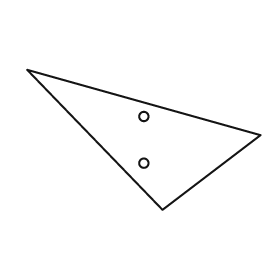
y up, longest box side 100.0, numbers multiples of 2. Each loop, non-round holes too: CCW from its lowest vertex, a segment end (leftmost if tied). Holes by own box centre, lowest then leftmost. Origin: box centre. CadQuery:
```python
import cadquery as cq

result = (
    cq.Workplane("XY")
    .moveTo(8.0, -30.0)
    .lineTo(50.0, 2.0)
    .lineTo(-50.0, 30.0)
    .close()
    .moveTo(0.0, -10.0)
    .circle(2.0)
    .moveTo(0.0, 10.0)
    .circle(2.0)
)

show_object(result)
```